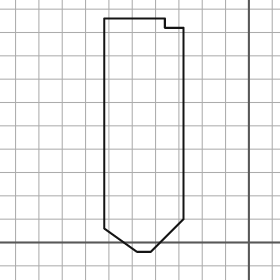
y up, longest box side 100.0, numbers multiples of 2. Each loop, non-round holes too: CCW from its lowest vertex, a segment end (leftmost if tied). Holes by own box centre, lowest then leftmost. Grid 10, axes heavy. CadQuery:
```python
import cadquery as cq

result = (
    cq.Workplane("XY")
    .moveTo(-48.0, -4.0)
    .lineTo(-42.0, -4.0)
    .lineTo(-28.0, 10.0)
    .lineTo(-28.0, 92.0)
    .lineTo(-36.0, 92.0)
    .lineTo(-36.0, 96.0)
    .lineTo(-62.0, 96.0)
    .lineTo(-62.0, 6.0)
    .close()
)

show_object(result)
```